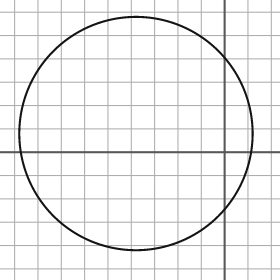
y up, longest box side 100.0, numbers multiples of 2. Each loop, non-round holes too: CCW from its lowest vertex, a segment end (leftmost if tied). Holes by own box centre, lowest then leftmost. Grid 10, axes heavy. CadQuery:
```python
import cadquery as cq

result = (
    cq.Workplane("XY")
    .moveTo(-38.0, 8.0)
    .circle(50.0)
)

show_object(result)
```